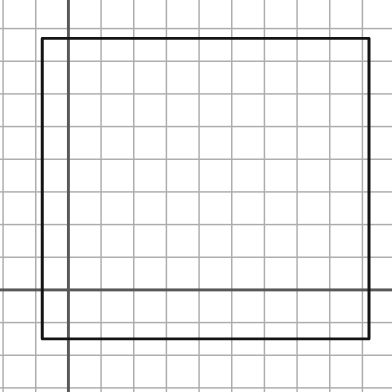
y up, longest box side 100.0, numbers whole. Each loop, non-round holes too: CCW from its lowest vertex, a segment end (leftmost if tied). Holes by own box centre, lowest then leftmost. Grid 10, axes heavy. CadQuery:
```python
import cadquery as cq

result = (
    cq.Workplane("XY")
    .moveTo(-8.0, -15.0)
    .lineTo(92.0, -15.0)
    .lineTo(92.0, 77.0)
    .lineTo(-8.0, 77.0)
    .close()
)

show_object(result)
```